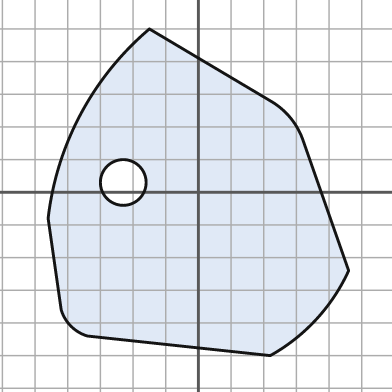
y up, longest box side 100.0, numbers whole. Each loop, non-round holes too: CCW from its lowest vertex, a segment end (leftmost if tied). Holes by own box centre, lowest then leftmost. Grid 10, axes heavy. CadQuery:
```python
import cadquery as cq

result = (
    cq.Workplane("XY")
    .moveTo(22.0, -50.0)
    .threePointArc((36.0, -39.0), (46.0, -24.0))
    .lineTo(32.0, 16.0)
    .threePointArc((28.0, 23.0), (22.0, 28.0))
    .lineTo(-15.0, 50.0)
    .threePointArc((-36.0, 24.0), (-46.0, -8.0))
    .lineTo(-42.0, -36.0)
    .threePointArc((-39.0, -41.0), (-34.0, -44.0))
    .close()
    .moveTo(-23.0, 3.0)
    .circle(7.0)
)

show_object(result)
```